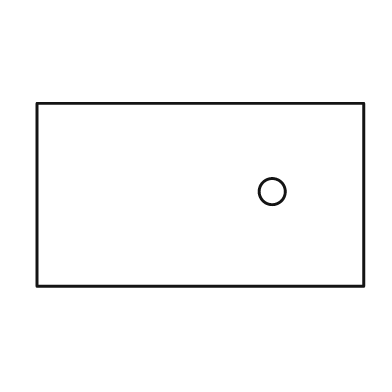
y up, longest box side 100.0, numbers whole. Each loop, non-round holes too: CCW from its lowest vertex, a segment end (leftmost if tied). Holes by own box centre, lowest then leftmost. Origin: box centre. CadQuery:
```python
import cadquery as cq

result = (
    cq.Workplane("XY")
    .moveTo(-50.0, -28.0)
    .lineTo(50.0, -28.0)
    .lineTo(50.0, 28.0)
    .lineTo(-50.0, 28.0)
    .close()
    .moveTo(22.0, 1.0)
    .circle(4.0)
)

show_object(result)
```